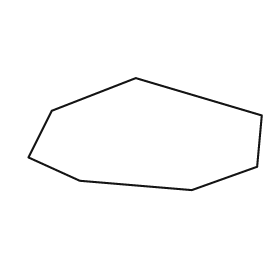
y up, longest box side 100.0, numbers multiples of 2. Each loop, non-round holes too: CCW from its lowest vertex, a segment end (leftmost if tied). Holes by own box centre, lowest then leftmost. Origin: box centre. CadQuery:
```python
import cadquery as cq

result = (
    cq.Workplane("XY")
    .moveTo(20.0, -24.0)
    .lineTo(48.0, -14.0)
    .lineTo(50.0, 8.0)
    .lineTo(-4.0, 24.0)
    .lineTo(-40.0, 10.0)
    .lineTo(-50.0, -10.0)
    .lineTo(-28.0, -20.0)
    .close()
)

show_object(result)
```